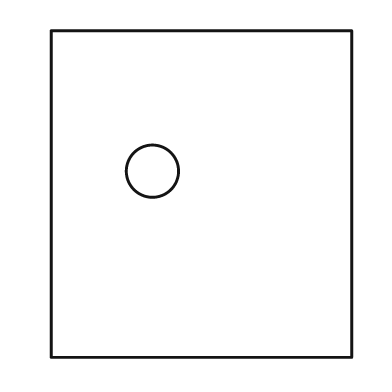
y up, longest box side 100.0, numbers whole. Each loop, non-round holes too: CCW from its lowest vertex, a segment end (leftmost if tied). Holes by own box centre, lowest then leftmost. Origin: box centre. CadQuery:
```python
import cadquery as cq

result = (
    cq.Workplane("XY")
    .moveTo(-46.0, -50.0)
    .lineTo(46.0, -50.0)
    .lineTo(46.0, 50.0)
    .lineTo(-46.0, 50.0)
    .close()
    .moveTo(-15.0, 7.0)
    .circle(8.0)
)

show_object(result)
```